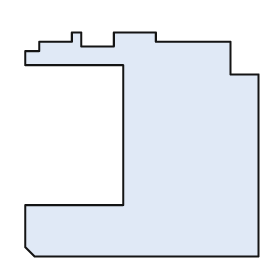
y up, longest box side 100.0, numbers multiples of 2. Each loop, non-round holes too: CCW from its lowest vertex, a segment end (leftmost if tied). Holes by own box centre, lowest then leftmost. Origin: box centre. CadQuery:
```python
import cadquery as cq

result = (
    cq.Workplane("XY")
    .moveTo(-46.0, -48.0)
    .lineTo(50.0, -48.0)
    .lineTo(50.0, 30.0)
    .lineTo(38.0, 30.0)
    .lineTo(38.0, 44.0)
    .lineTo(6.0, 44.0)
    .lineTo(6.0, 48.0)
    .lineTo(-12.0, 48.0)
    .lineTo(-12.0, 42.0)
    .lineTo(-26.0, 42.0)
    .lineTo(-26.0, 48.0)
    .lineTo(-30.0, 48.0)
    .lineTo(-30.0, 44.0)
    .lineTo(-44.0, 44.0)
    .lineTo(-44.0, 40.0)
    .lineTo(-50.0, 40.0)
    .lineTo(-50.0, 34.0)
    .lineTo(-8.0, 34.0)
    .lineTo(-8.0, -26.0)
    .lineTo(-50.0, -26.0)
    .lineTo(-50.0, -44.0)
    .close()
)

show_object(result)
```